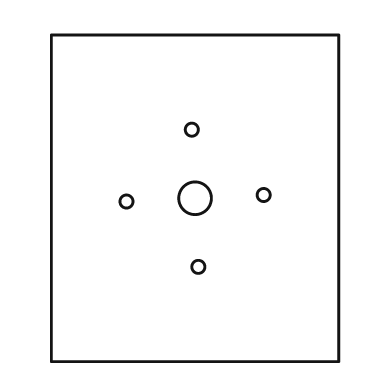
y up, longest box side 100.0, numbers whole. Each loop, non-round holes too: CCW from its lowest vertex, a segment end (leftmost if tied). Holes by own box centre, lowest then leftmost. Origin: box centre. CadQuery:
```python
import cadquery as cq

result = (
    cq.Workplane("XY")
    .moveTo(-44.0, -50.0)
    .lineTo(44.0, -50.0)
    .lineTo(44.0, 50.0)
    .lineTo(-44.0, 50.0)
    .close()
    .moveTo(1.0, -21.0)
    .circle(2.0)
    .moveTo(-21.0, -1.0)
    .circle(2.0)
    .moveTo(0.0, 0.0)
    .circle(5.0)
    .moveTo(21.0, 1.0)
    .circle(2.0)
    .moveTo(-1.0, 21.0)
    .circle(2.0)
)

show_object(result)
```